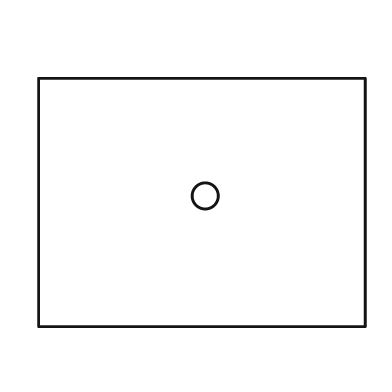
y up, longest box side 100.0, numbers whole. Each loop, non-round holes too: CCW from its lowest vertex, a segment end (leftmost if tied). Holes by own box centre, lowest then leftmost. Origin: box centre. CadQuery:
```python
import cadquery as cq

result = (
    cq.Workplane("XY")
    .moveTo(-50.0, -38.0)
    .lineTo(50.0, -38.0)
    .lineTo(50.0, 38.0)
    .lineTo(-50.0, 38.0)
    .close()
    .moveTo(1.0, 2.0)
    .circle(4.0)
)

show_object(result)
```